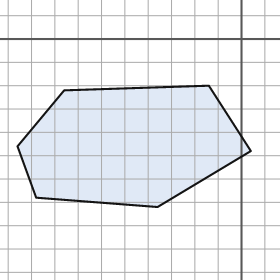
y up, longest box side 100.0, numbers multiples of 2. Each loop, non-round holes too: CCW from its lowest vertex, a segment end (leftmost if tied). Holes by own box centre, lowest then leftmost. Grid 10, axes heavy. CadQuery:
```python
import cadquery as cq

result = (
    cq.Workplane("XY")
    .moveTo(-36.0, -72.0)
    .lineTo(4.0, -48.0)
    .lineTo(-14.0, -20.0)
    .lineTo(-76.0, -22.0)
    .lineTo(-96.0, -46.0)
    .lineTo(-88.0, -68.0)
    .close()
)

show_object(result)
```